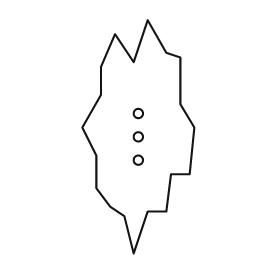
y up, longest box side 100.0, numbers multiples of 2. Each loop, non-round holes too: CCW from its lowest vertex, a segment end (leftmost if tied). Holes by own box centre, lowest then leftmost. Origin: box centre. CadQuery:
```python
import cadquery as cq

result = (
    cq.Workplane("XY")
    .moveTo(-2.0, -50.0)
    .lineTo(4.0, -32.0)
    .lineTo(12.0, -32.0)
    .lineTo(14.0, -16.0)
    .lineTo(22.0, -16.0)
    .lineTo(24.0, 4.0)
    .lineTo(18.0, 14.0)
    .lineTo(18.0, 34.0)
    .lineTo(12.0, 36.0)
    .lineTo(4.0, 50.0)
    .lineTo(-2.0, 32.0)
    .lineTo(-10.0, 44.0)
    .lineTo(-16.0, 30.0)
    .lineTo(-16.0, 18.0)
    .lineTo(-24.0, 4.0)
    .lineTo(-18.0, -8.0)
    .lineTo(-18.0, -22.0)
    .lineTo(-12.0, -30.0)
    .lineTo(-6.0, -34.0)
    .close()
    .moveTo(0.0, -10.0)
    .circle(2.0)
    .moveTo(0.0, 0.0)
    .circle(2.0)
    .moveTo(0.0, 10.0)
    .circle(2.0)
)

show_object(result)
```